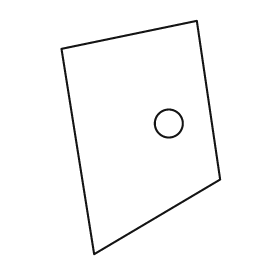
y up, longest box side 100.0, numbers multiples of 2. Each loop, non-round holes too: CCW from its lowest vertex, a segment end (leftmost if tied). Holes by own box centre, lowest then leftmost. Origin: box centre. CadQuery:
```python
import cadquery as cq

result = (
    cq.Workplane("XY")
    .moveTo(-20.0, -50.0)
    .lineTo(34.0, -18.0)
    .lineTo(24.0, 50.0)
    .lineTo(-34.0, 38.0)
    .close()
    .moveTo(12.0, 6.0)
    .circle(6.0)
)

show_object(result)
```